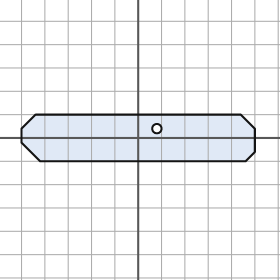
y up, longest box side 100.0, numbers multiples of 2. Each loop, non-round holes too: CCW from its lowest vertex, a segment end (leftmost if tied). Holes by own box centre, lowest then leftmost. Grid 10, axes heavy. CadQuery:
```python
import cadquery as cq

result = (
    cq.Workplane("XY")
    .moveTo(-42.0, -10.0)
    .lineTo(46.0, -10.0)
    .lineTo(50.0, -6.0)
    .lineTo(50.0, 4.0)
    .lineTo(44.0, 10.0)
    .lineTo(-44.0, 10.0)
    .lineTo(-50.0, 4.0)
    .lineTo(-50.0, -2.0)
    .close()
    .moveTo(8.0, 4.0)
    .circle(2.0)
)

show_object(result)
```